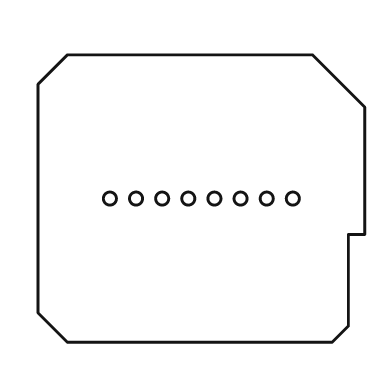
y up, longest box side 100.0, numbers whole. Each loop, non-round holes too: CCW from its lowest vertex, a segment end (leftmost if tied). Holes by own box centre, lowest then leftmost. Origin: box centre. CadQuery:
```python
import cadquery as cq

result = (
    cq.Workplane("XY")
    .moveTo(-41.0, -44.0)
    .lineTo(40.0, -44.0)
    .lineTo(45.0, -39.0)
    .lineTo(45.0, -11.0)
    .lineTo(50.0, -11.0)
    .lineTo(50.0, 28.0)
    .lineTo(34.0, 44.0)
    .lineTo(-41.0, 44.0)
    .lineTo(-50.0, 35.0)
    .lineTo(-50.0, -35.0)
    .close()
    .moveTo(-28.0, 0.0)
    .circle(2.0)
    .moveTo(-20.0, 0.0)
    .circle(2.0)
    .moveTo(-12.0, 0.0)
    .circle(2.0)
    .moveTo(-4.0, 0.0)
    .circle(2.0)
    .moveTo(4.0, 0.0)
    .circle(2.0)
    .moveTo(12.0, 0.0)
    .circle(2.0)
    .moveTo(20.0, 0.0)
    .circle(2.0)
    .moveTo(28.0, 0.0)
    .circle(2.0)
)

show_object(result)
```